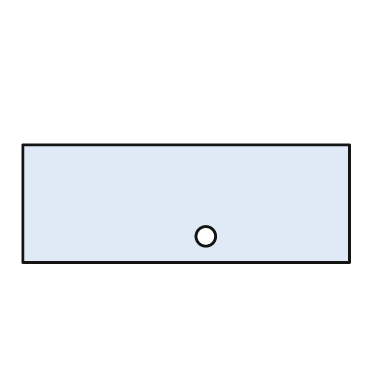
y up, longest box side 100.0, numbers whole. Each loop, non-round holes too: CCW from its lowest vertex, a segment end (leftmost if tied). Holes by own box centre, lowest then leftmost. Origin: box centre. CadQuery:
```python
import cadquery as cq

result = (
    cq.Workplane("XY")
    .moveTo(-50.0, -18.0)
    .lineTo(50.0, -18.0)
    .lineTo(50.0, 18.0)
    .lineTo(-50.0, 18.0)
    .close()
    .moveTo(6.0, -10.0)
    .circle(3.0)
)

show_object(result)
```